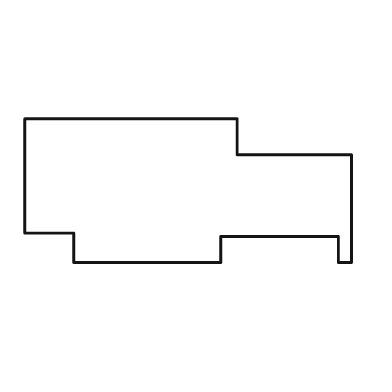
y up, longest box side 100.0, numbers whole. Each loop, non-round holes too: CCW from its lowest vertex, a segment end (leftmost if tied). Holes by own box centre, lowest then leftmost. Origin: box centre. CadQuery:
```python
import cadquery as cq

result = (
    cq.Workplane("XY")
    .moveTo(-35.0, -22.0)
    .lineTo(10.0, -22.0)
    .lineTo(10.0, -14.0)
    .lineTo(46.0, -14.0)
    .lineTo(46.0, -22.0)
    .lineTo(50.0, -22.0)
    .lineTo(50.0, 11.0)
    .lineTo(15.0, 11.0)
    .lineTo(15.0, 22.0)
    .lineTo(-50.0, 22.0)
    .lineTo(-50.0, -13.0)
    .lineTo(-35.0, -13.0)
    .close()
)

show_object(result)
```